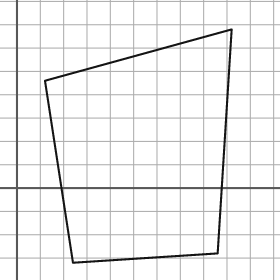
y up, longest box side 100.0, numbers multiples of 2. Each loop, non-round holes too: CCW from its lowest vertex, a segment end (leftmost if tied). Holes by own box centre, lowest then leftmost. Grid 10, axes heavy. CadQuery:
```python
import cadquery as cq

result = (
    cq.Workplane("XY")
    .moveTo(24.0, -32.0)
    .lineTo(86.0, -28.0)
    .lineTo(92.0, 68.0)
    .lineTo(12.0, 46.0)
    .close()
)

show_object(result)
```